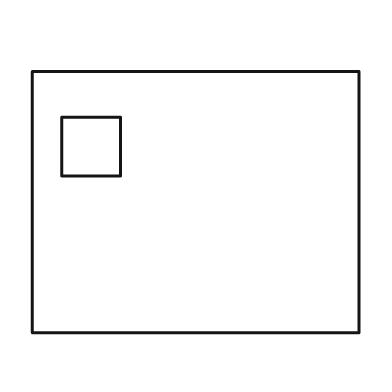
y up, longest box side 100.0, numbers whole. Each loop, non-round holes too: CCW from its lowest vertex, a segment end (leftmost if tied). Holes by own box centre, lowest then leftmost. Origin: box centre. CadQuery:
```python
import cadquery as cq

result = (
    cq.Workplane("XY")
    .moveTo(-50.0, -40.0)
    .lineTo(50.0, -40.0)
    .lineTo(50.0, 40.0)
    .lineTo(-50.0, 40.0)
    .close()
    .moveTo(-41.0, 8.0)
    .lineTo(-23.0, 8.0)
    .lineTo(-23.0, 26.0)
    .lineTo(-41.0, 26.0)
    .close()
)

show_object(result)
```